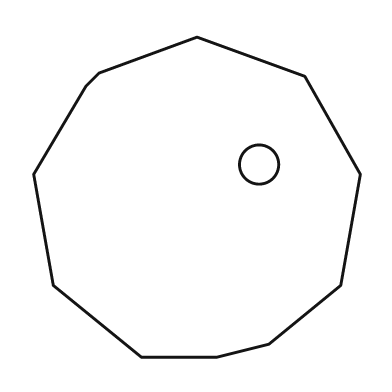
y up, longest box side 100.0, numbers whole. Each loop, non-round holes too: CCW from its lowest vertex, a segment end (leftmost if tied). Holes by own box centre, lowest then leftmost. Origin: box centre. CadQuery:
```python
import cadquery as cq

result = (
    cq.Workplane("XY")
    .moveTo(-17.0, -49.0)
    .lineTo(6.0, -49.0)
    .lineTo(22.0, -45.0)
    .lineTo(44.0, -27.0)
    .lineTo(50.0, 7.0)
    .lineTo(33.0, 37.0)
    .lineTo(0.0, 49.0)
    .lineTo(-30.0, 38.0)
    .lineTo(-34.0, 34.0)
    .lineTo(-50.0, 7.0)
    .lineTo(-44.0, -27.0)
    .close()
    .moveTo(19.0, 10.0)
    .circle(6.0)
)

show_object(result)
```